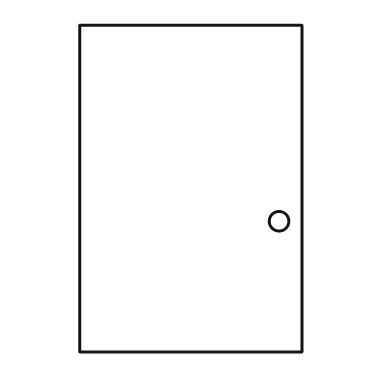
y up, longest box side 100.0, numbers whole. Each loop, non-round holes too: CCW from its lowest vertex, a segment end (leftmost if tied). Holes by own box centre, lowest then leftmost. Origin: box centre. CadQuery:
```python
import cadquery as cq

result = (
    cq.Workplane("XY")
    .moveTo(-34.0, -50.0)
    .lineTo(34.0, -50.0)
    .lineTo(34.0, 50.0)
    .lineTo(-34.0, 50.0)
    .close()
    .moveTo(27.0, -10.0)
    .circle(3.0)
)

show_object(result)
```